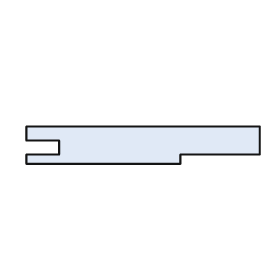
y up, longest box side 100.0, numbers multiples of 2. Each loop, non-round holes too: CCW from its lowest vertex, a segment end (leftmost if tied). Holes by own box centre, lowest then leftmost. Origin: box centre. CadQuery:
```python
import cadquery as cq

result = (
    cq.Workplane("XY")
    .moveTo(-50.0, -8.0)
    .lineTo(16.0, -8.0)
    .lineTo(16.0, -4.0)
    .lineTo(50.0, -4.0)
    .lineTo(50.0, 8.0)
    .lineTo(-50.0, 8.0)
    .lineTo(-50.0, 2.0)
    .lineTo(-36.0, 2.0)
    .lineTo(-36.0, -4.0)
    .lineTo(-50.0, -4.0)
    .close()
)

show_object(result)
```